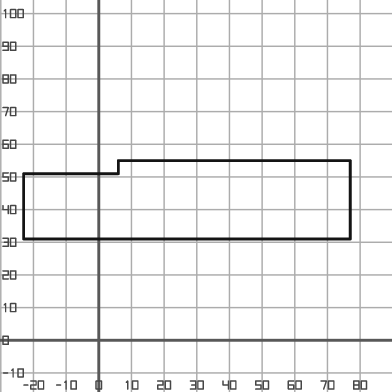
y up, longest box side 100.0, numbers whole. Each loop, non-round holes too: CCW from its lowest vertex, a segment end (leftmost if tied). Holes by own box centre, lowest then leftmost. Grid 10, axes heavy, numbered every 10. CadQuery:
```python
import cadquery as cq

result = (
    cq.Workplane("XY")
    .moveTo(-23.0, 31.0)
    .lineTo(77.0, 31.0)
    .lineTo(77.0, 55.0)
    .lineTo(6.0, 55.0)
    .lineTo(6.0, 51.0)
    .lineTo(-23.0, 51.0)
    .close()
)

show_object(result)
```